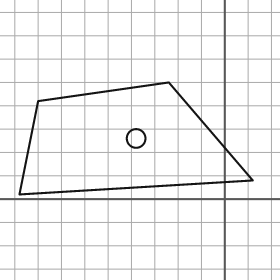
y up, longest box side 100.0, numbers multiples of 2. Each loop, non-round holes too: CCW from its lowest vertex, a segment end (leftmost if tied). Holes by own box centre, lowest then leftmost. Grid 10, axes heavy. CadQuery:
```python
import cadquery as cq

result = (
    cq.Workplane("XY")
    .moveTo(-88.0, 2.0)
    .lineTo(12.0, 8.0)
    .lineTo(-24.0, 50.0)
    .lineTo(-80.0, 42.0)
    .close()
    .moveTo(-38.0, 26.0)
    .circle(4.0)
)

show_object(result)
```